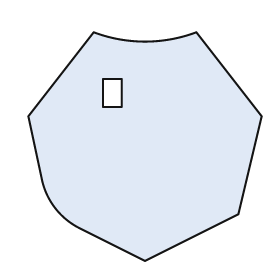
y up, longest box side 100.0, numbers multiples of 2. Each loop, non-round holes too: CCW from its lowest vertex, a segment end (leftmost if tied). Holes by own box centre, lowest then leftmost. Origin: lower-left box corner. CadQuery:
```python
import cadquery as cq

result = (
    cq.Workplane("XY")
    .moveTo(50.0, 0.0)
    .lineTo(90.0, 20.0)
    .lineTo(100.0, 62.0)
    .lineTo(72.0, 98.0)
    .threePointArc((50.0, 94.0), (28.0, 98.0))
    .lineTo(0.0, 62.0)
    .lineTo(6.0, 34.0)
    .threePointArc((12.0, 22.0), (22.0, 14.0))
    .close()
    .moveTo(32.0, 66.0)
    .lineTo(40.0, 66.0)
    .lineTo(40.0, 78.0)
    .lineTo(32.0, 78.0)
    .close()
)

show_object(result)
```